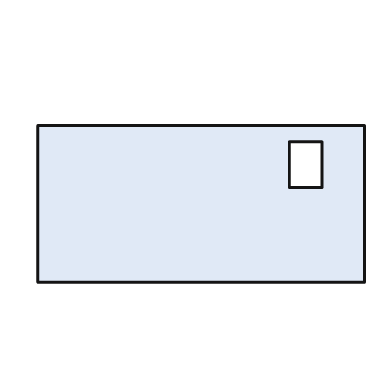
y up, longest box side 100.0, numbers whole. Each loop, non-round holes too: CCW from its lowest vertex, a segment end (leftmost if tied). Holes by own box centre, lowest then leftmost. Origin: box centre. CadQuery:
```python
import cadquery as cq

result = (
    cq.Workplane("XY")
    .moveTo(-50.0, -24.0)
    .lineTo(50.0, -24.0)
    .lineTo(50.0, 24.0)
    .lineTo(-50.0, 24.0)
    .close()
    .moveTo(27.0, 5.0)
    .lineTo(37.0, 5.0)
    .lineTo(37.0, 19.0)
    .lineTo(27.0, 19.0)
    .close()
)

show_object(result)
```